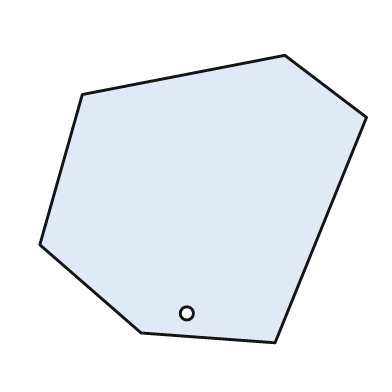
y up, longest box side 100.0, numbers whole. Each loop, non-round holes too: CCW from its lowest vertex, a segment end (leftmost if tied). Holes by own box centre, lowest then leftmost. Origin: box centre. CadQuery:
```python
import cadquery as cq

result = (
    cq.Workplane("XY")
    .moveTo(22.0, -44.0)
    .lineTo(50.0, 25.0)
    .lineTo(25.0, 44.0)
    .lineTo(-37.0, 32.0)
    .lineTo(-50.0, -14.0)
    .lineTo(-19.0, -41.0)
    .close()
    .moveTo(-5.0, -35.0)
    .circle(2.0)
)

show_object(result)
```